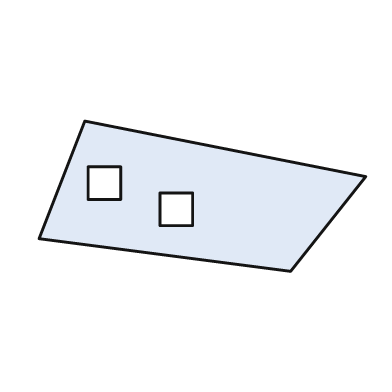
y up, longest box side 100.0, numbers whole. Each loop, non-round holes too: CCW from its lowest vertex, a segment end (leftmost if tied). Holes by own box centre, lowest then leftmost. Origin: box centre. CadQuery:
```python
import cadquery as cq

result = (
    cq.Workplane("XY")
    .moveTo(27.0, -23.0)
    .lineTo(50.0, 6.0)
    .lineTo(-36.0, 23.0)
    .lineTo(-50.0, -13.0)
    .close()
    .moveTo(-13.0, -9.0)
    .lineTo(-3.0, -9.0)
    .lineTo(-3.0, 1.0)
    .lineTo(-13.0, 1.0)
    .close()
    .moveTo(-35.0, -1.0)
    .lineTo(-25.0, -1.0)
    .lineTo(-25.0, 9.0)
    .lineTo(-35.0, 9.0)
    .close()
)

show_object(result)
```